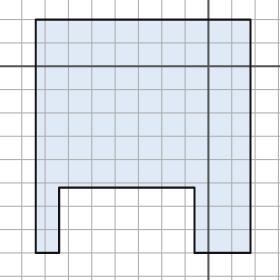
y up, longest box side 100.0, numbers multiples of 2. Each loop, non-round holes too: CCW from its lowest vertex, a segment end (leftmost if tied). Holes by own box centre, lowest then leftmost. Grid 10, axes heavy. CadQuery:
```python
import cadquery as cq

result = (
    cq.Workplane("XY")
    .moveTo(-74.0, -80.0)
    .lineTo(-64.0, -80.0)
    .lineTo(-64.0, -52.0)
    .lineTo(-6.0, -52.0)
    .lineTo(-6.0, -80.0)
    .lineTo(18.0, -80.0)
    .lineTo(18.0, 20.0)
    .lineTo(-74.0, 20.0)
    .close()
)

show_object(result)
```